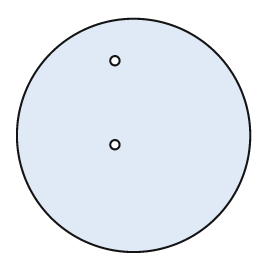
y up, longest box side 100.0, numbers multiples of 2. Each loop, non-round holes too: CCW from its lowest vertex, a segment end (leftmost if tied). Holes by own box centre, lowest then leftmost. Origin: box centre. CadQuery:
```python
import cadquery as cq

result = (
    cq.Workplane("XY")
    .moveTo(0.0, 0.0)
    .circle(50.0)
    .moveTo(-8.0, -4.0)
    .circle(2.0)
    .moveTo(-8.0, 32.0)
    .circle(2.0)
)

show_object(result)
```